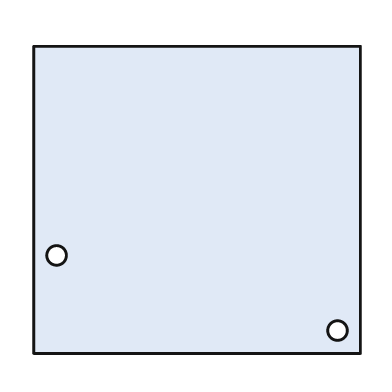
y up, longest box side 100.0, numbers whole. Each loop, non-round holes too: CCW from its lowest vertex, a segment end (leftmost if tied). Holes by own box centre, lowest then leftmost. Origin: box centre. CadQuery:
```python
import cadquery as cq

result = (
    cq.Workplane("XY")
    .moveTo(-50.0, -47.0)
    .lineTo(50.0, -47.0)
    .lineTo(50.0, 47.0)
    .lineTo(-50.0, 47.0)
    .close()
    .moveTo(43.0, -40.0)
    .circle(3.0)
    .moveTo(-43.0, -17.0)
    .circle(3.0)
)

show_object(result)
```